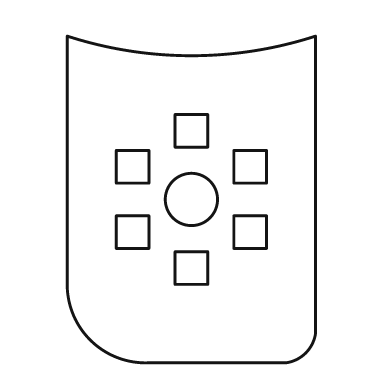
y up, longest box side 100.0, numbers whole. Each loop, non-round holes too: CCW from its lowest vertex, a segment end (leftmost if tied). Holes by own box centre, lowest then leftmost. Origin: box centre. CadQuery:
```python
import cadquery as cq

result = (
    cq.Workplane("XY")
    .moveTo(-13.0, -50.0)
    .lineTo(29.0, -50.0)
    .threePointArc((35.0, -47.0), (38.0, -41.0))
    .lineTo(38.0, 50.0)
    .threePointArc((0.0, 44.0), (-38.0, 50.0))
    .lineTo(-38.0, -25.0)
    .threePointArc((-31.0, -43.0), (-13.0, -50.0))
    .close()
    .moveTo(-5.0, -26.0)
    .lineTo(5.0, -26.0)
    .lineTo(5.0, -16.0)
    .lineTo(-5.0, -16.0)
    .close()
    .moveTo(-23.0, -15.0)
    .lineTo(-13.0, -15.0)
    .lineTo(-13.0, -5.0)
    .lineTo(-23.0, -5.0)
    .close()
    .moveTo(13.0, -15.0)
    .lineTo(23.0, -15.0)
    .lineTo(23.0, -5.0)
    .lineTo(13.0, -5.0)
    .close()
    .moveTo(0.0, 0.0)
    .circle(8.0)
    .moveTo(-23.0, 5.0)
    .lineTo(-13.0, 5.0)
    .lineTo(-13.0, 15.0)
    .lineTo(-23.0, 15.0)
    .close()
    .moveTo(13.0, 5.0)
    .lineTo(23.0, 5.0)
    .lineTo(23.0, 15.0)
    .lineTo(13.0, 15.0)
    .close()
    .moveTo(-5.0, 16.0)
    .lineTo(5.0, 16.0)
    .lineTo(5.0, 26.0)
    .lineTo(-5.0, 26.0)
    .close()
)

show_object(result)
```